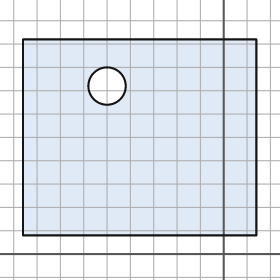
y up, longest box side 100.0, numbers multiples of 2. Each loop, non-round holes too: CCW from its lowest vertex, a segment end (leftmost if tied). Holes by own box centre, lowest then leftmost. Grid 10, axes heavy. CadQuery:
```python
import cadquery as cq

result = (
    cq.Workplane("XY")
    .moveTo(-86.0, 8.0)
    .lineTo(14.0, 8.0)
    .lineTo(14.0, 92.0)
    .lineTo(-86.0, 92.0)
    .close()
    .moveTo(-50.0, 72.0)
    .circle(8.0)
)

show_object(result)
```